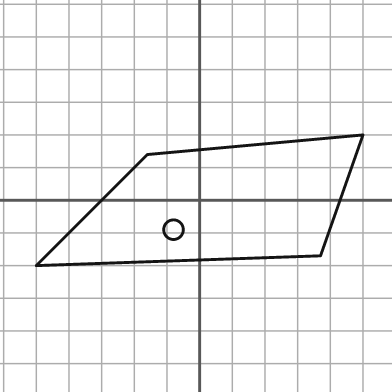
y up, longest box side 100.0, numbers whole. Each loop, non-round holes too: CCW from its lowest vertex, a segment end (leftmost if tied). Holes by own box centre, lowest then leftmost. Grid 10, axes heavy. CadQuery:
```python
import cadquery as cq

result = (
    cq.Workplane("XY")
    .moveTo(-50.0, -20.0)
    .lineTo(37.0, -17.0)
    .lineTo(50.0, 20.0)
    .lineTo(-16.0, 14.0)
    .close()
    .moveTo(-8.0, -9.0)
    .circle(3.0)
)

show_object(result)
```